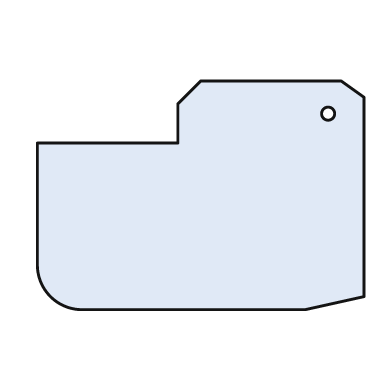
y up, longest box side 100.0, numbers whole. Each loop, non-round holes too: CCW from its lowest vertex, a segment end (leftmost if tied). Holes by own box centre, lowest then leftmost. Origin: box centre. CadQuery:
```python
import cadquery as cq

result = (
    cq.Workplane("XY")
    .moveTo(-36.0, -35.0)
    .lineTo(32.0, -35.0)
    .lineTo(50.0, -31.0)
    .lineTo(50.0, 30.0)
    .lineTo(43.0, 35.0)
    .lineTo(0.0, 35.0)
    .lineTo(-7.0, 28.0)
    .lineTo(-7.0, 16.0)
    .lineTo(-50.0, 16.0)
    .lineTo(-50.0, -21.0)
    .threePointArc((-46.0, -31.0), (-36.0, -35.0))
    .close()
    .moveTo(39.0, 25.0)
    .circle(2.0)
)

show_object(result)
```